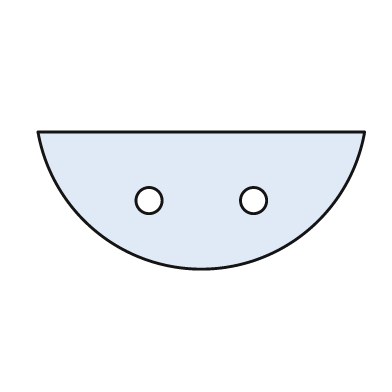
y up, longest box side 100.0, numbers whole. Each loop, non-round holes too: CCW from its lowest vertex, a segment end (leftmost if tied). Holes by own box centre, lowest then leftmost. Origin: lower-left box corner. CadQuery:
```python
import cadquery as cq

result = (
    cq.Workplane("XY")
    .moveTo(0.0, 42.0)
    .threePointArc((50.0, 0.0), (100.0, 42.0))
    .close()
    .moveTo(34.0, 21.0)
    .circle(4.0)
    .moveTo(66.0, 21.0)
    .circle(4.0)
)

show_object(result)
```